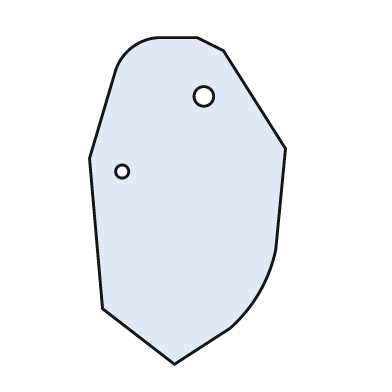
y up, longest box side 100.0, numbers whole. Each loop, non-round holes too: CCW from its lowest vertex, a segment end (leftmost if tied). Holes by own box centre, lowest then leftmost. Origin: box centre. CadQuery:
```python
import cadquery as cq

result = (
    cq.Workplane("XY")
    .moveTo(-4.0, -50.0)
    .lineTo(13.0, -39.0)
    .threePointArc((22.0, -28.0), (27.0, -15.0))
    .lineTo(30.0, 16.0)
    .lineTo(11.0, 46.0)
    .lineTo(3.0, 50.0)
    .lineTo(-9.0, 50.0)
    .threePointArc((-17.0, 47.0), (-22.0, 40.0))
    .lineTo(-30.0, 13.0)
    .lineTo(-26.0, -33.0)
    .close()
    .moveTo(-20.0, 9.0)
    .circle(2.0)
    .moveTo(5.0, 32.0)
    .circle(3.0)
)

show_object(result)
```